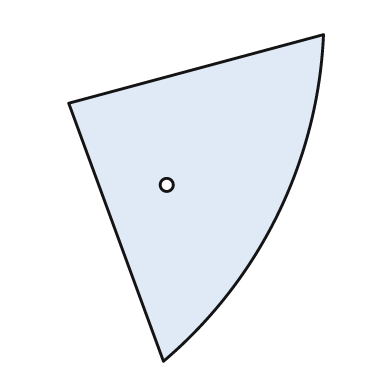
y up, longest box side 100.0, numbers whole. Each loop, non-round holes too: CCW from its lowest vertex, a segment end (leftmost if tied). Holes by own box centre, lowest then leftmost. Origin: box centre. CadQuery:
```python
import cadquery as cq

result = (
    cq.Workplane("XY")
    .moveTo(-10.0, -50.0)
    .threePointArc((25.0, -5.0), (39.0, 50.0))
    .lineTo(-39.0, 29.0)
    .close()
    .moveTo(-9.0, 4.0)
    .circle(2.0)
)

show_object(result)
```